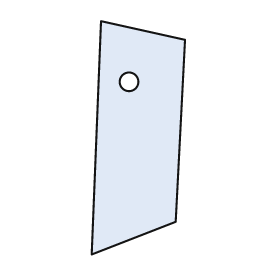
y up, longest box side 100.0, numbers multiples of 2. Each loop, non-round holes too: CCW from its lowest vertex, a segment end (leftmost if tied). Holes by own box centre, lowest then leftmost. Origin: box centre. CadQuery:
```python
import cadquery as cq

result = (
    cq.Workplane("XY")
    .moveTo(-20.0, -50.0)
    .lineTo(16.0, -36.0)
    .lineTo(20.0, 42.0)
    .lineTo(-16.0, 50.0)
    .close()
    .moveTo(-4.0, 24.0)
    .circle(4.0)
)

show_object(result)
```